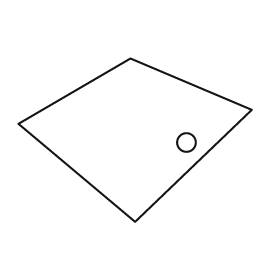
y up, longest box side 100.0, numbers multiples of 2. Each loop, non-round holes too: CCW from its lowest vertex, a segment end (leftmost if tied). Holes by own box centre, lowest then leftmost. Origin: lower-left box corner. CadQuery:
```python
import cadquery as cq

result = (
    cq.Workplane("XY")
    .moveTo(50.0, 0.0)
    .lineTo(100.0, 48.0)
    .lineTo(48.0, 70.0)
    .lineTo(0.0, 42.0)
    .close()
    .moveTo(72.0, 34.0)
    .circle(4.0)
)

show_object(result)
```